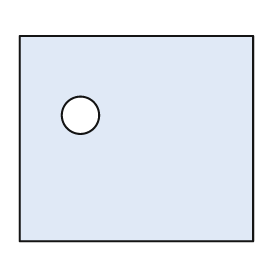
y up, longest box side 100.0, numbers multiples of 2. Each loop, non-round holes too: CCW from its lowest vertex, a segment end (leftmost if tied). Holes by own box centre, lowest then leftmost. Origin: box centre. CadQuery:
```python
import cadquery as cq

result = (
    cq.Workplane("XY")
    .moveTo(-50.0, -44.0)
    .lineTo(50.0, -44.0)
    .lineTo(50.0, 44.0)
    .lineTo(-50.0, 44.0)
    .close()
    .moveTo(-24.0, 10.0)
    .circle(8.0)
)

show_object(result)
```